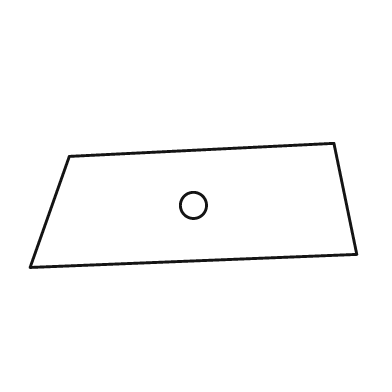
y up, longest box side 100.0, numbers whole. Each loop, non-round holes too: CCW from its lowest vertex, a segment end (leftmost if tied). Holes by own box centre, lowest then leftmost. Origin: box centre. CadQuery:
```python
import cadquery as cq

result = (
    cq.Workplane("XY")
    .moveTo(-50.0, -19.0)
    .lineTo(50.0, -15.0)
    .lineTo(43.0, 19.0)
    .lineTo(-38.0, 15.0)
    .close()
    .moveTo(0.0, 0.0)
    .circle(4.0)
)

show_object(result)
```